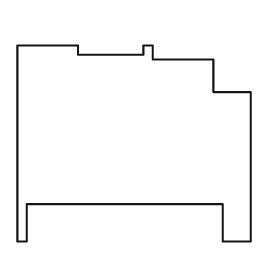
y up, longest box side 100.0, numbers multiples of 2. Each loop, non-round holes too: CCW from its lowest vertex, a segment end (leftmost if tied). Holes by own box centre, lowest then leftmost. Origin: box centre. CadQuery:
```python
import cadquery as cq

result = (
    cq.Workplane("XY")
    .moveTo(-50.0, -42.0)
    .lineTo(-46.0, -42.0)
    .lineTo(-46.0, -26.0)
    .lineTo(38.0, -26.0)
    .lineTo(38.0, -42.0)
    .lineTo(50.0, -42.0)
    .lineTo(50.0, 22.0)
    .lineTo(34.0, 22.0)
    .lineTo(34.0, 36.0)
    .lineTo(8.0, 36.0)
    .lineTo(8.0, 42.0)
    .lineTo(4.0, 42.0)
    .lineTo(4.0, 38.0)
    .lineTo(-24.0, 38.0)
    .lineTo(-24.0, 42.0)
    .lineTo(-50.0, 42.0)
    .close()
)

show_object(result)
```